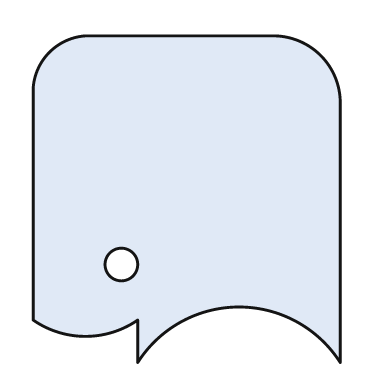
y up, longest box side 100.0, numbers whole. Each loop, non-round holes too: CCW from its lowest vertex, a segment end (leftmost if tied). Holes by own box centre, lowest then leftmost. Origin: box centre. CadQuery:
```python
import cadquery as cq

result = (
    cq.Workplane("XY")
    .moveTo(-15.0, -50.0)
    .threePointArc((16.0, -33.0), (47.0, -50.0))
    .lineTo(47.0, 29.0)
    .threePointArc((41.0, 44.0), (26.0, 50.0))
    .lineTo(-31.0, 50.0)
    .threePointArc((-42.0, 45.0), (-47.0, 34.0))
    .lineTo(-47.0, -37.0)
    .threePointArc((-31.0, -42.0), (-15.0, -37.0))
    .close()
    .moveTo(-20.0, -20.0)
    .circle(5.0)
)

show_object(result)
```